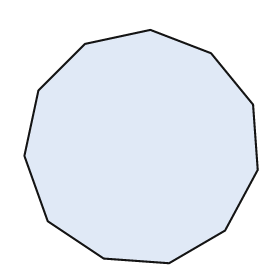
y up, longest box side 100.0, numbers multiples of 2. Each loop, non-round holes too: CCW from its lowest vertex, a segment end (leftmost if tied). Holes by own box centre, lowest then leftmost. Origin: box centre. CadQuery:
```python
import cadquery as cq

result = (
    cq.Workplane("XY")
    .moveTo(12.0, -50.0)
    .lineTo(36.0, -36.0)
    .lineTo(50.0, -10.0)
    .lineTo(48.0, 18.0)
    .lineTo(30.0, 40.0)
    .lineTo(4.0, 50.0)
    .lineTo(-24.0, 44.0)
    .lineTo(-44.0, 24.0)
    .lineTo(-50.0, -4.0)
    .lineTo(-40.0, -32.0)
    .lineTo(-16.0, -48.0)
    .close()
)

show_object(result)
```